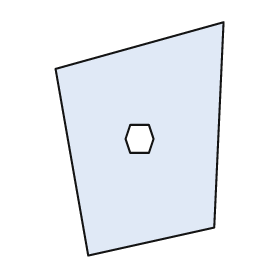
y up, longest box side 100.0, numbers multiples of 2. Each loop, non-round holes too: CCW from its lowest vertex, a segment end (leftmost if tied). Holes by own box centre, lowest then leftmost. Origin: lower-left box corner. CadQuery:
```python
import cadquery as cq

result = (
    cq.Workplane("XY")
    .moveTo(14.0, 0.0)
    .lineTo(68.0, 12.0)
    .lineTo(72.0, 100.0)
    .lineTo(0.0, 80.0)
    .close()
    .moveTo(32.0, 44.0)
    .lineTo(40.0, 44.0)
    .lineTo(42.0, 50.0)
    .lineTo(40.0, 56.0)
    .lineTo(32.0, 56.0)
    .lineTo(30.0, 50.0)
    .close()
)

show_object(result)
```